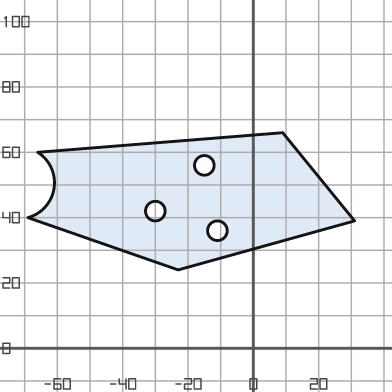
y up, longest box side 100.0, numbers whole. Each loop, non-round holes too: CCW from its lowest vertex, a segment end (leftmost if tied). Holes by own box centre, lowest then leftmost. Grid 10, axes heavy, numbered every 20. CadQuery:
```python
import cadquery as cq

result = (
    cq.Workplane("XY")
    .moveTo(-23.0, 24.0)
    .lineTo(31.0, 39.0)
    .lineTo(9.0, 66.0)
    .lineTo(-66.0, 60.0)
    .threePointArc((-61.0, 49.0), (-69.0, 40.0))
    .close()
    .moveTo(-11.0, 36.0)
    .circle(3.0)
    .moveTo(-30.0, 42.0)
    .circle(3.0)
    .moveTo(-15.0, 56.0)
    .circle(3.0)
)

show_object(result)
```